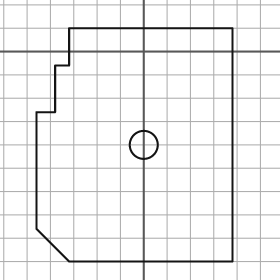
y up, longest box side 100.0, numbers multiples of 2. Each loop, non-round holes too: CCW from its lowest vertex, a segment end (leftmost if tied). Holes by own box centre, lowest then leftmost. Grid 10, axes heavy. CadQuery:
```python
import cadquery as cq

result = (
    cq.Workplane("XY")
    .moveTo(-32.0, -90.0)
    .lineTo(38.0, -90.0)
    .lineTo(38.0, 10.0)
    .lineTo(-32.0, 10.0)
    .lineTo(-32.0, -6.0)
    .lineTo(-38.0, -6.0)
    .lineTo(-38.0, -26.0)
    .lineTo(-46.0, -26.0)
    .lineTo(-46.0, -76.0)
    .close()
    .moveTo(0.0, -40.0)
    .circle(6.0)
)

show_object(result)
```